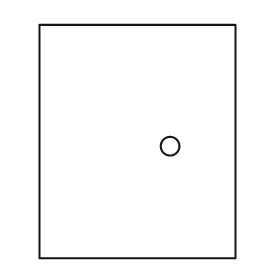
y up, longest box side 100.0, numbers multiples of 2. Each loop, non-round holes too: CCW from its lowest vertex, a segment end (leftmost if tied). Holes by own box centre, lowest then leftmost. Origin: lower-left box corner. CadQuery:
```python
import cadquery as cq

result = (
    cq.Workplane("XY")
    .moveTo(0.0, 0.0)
    .lineTo(84.0, 0.0)
    .lineTo(84.0, 100.0)
    .lineTo(0.0, 100.0)
    .close()
    .moveTo(56.0, 48.0)
    .circle(4.0)
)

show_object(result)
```